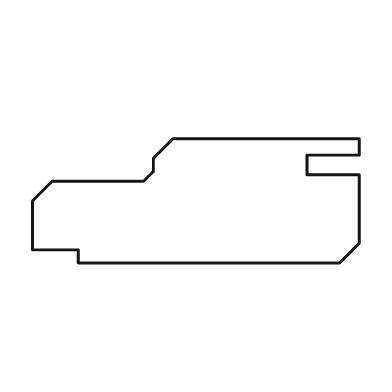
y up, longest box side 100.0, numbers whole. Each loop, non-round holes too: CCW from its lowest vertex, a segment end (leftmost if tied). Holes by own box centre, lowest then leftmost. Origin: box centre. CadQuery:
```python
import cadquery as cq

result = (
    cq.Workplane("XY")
    .moveTo(-36.0, -19.0)
    .lineTo(44.0, -19.0)
    .lineTo(50.0, -13.0)
    .lineTo(50.0, 8.0)
    .lineTo(34.0, 8.0)
    .lineTo(34.0, 14.0)
    .lineTo(50.0, 14.0)
    .lineTo(50.0, 19.0)
    .lineTo(-7.0, 19.0)
    .lineTo(-13.0, 13.0)
    .lineTo(-13.0, 9.0)
    .lineTo(-16.0, 6.0)
    .lineTo(-44.0, 6.0)
    .lineTo(-50.0, 0.0)
    .lineTo(-50.0, -15.0)
    .lineTo(-36.0, -15.0)
    .close()
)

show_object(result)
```